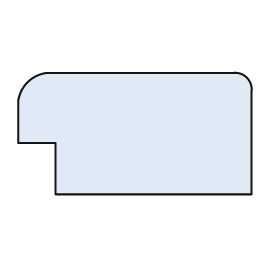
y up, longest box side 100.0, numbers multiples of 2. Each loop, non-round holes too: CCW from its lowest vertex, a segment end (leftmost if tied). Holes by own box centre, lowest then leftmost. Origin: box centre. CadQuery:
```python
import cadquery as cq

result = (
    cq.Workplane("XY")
    .moveTo(-34.0, -26.0)
    .lineTo(50.0, -26.0)
    .lineTo(50.0, 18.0)
    .threePointArc((48.0, 24.0), (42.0, 26.0))
    .lineTo(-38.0, 26.0)
    .threePointArc((-46.0, 22.0), (-50.0, 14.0))
    .lineTo(-50.0, -4.0)
    .lineTo(-34.0, -4.0)
    .close()
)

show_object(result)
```